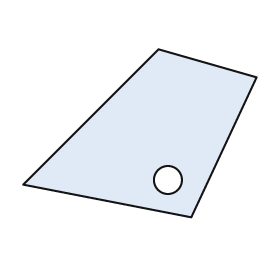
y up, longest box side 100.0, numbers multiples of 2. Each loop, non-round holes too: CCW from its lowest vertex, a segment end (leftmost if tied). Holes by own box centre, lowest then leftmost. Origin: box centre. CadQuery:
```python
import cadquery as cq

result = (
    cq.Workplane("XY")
    .moveTo(22.0, -36.0)
    .lineTo(50.0, 24.0)
    .lineTo(8.0, 36.0)
    .lineTo(-50.0, -22.0)
    .close()
    .moveTo(12.0, -20.0)
    .circle(6.0)
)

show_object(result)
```